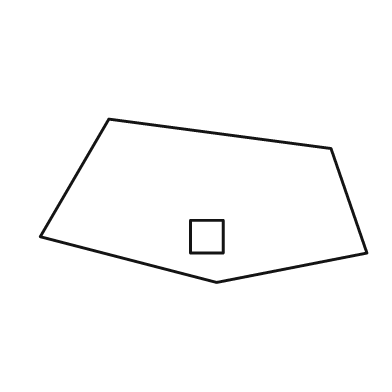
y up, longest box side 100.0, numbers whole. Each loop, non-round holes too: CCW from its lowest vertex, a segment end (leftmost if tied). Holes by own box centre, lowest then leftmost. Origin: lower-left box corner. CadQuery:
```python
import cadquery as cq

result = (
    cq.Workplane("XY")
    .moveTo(54.0, 0.0)
    .lineTo(100.0, 9.0)
    .lineTo(89.0, 41.0)
    .lineTo(21.0, 50.0)
    .lineTo(0.0, 14.0)
    .close()
    .moveTo(46.0, 9.0)
    .lineTo(56.0, 9.0)
    .lineTo(56.0, 19.0)
    .lineTo(46.0, 19.0)
    .close()
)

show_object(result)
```